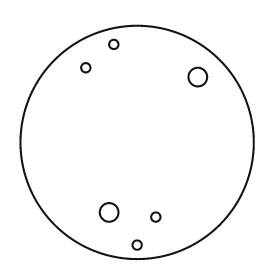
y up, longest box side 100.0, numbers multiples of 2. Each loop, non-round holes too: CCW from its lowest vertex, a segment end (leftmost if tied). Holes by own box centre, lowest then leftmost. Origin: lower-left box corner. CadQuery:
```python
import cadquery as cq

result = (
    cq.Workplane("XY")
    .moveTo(50.0, 50.0)
    .circle(50.0)
    .moveTo(50.0, 6.0)
    .circle(2.0)
    .moveTo(58.0, 18.0)
    .circle(2.0)
    .moveTo(38.0, 20.0)
    .circle(4.0)
    .moveTo(76.0, 78.0)
    .circle(4.0)
    .moveTo(28.0, 82.0)
    .circle(2.0)
    .moveTo(40.0, 92.0)
    .circle(2.0)
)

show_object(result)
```